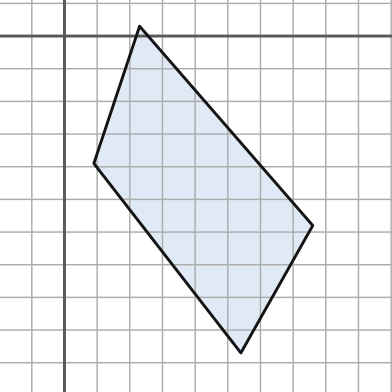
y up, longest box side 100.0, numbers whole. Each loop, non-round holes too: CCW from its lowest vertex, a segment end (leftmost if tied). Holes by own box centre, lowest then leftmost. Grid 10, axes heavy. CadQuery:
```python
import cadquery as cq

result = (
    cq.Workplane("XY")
    .moveTo(54.0, -97.0)
    .lineTo(76.0, -58.0)
    .lineTo(23.0, 3.0)
    .lineTo(9.0, -39.0)
    .close()
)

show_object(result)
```